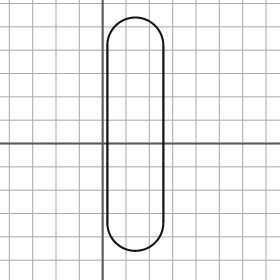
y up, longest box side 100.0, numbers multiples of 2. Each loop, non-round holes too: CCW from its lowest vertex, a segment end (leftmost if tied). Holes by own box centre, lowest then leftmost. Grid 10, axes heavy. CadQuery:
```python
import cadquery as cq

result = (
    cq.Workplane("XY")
    .moveTo(2.0, -34.0)
    .threePointArc((14.0, -46.0), (26.0, -34.0))
    .lineTo(26.0, 42.0)
    .threePointArc((14.0, 54.0), (2.0, 42.0))
    .close()
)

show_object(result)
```